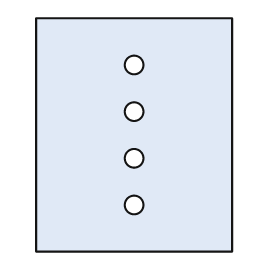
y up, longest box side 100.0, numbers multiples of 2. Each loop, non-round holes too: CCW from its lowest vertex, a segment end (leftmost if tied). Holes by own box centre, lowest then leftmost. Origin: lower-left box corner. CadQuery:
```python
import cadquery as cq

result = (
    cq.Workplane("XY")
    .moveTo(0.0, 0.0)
    .lineTo(84.0, 0.0)
    .lineTo(84.0, 100.0)
    .lineTo(0.0, 100.0)
    .close()
    .moveTo(42.0, 20.0)
    .circle(4.0)
    .moveTo(42.0, 40.0)
    .circle(4.0)
    .moveTo(42.0, 60.0)
    .circle(4.0)
    .moveTo(42.0, 80.0)
    .circle(4.0)
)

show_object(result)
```